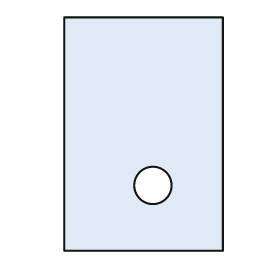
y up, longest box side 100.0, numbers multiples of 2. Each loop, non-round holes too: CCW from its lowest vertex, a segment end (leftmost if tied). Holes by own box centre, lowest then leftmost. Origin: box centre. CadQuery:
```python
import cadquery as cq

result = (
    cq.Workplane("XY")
    .moveTo(-34.0, -50.0)
    .lineTo(34.0, -50.0)
    .lineTo(34.0, 50.0)
    .lineTo(-34.0, 50.0)
    .close()
    .moveTo(4.0, -22.0)
    .circle(8.0)
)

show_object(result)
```